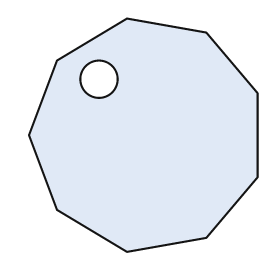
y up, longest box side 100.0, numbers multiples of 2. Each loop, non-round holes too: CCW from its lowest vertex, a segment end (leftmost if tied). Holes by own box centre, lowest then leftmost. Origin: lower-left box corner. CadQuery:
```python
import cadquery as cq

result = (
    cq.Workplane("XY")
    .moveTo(42.0, 0.0)
    .lineTo(76.0, 6.0)
    .lineTo(98.0, 32.0)
    .lineTo(98.0, 68.0)
    .lineTo(76.0, 94.0)
    .lineTo(42.0, 100.0)
    .lineTo(12.0, 82.0)
    .lineTo(0.0, 50.0)
    .lineTo(12.0, 18.0)
    .close()
    .moveTo(30.0, 74.0)
    .circle(8.0)
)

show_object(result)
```